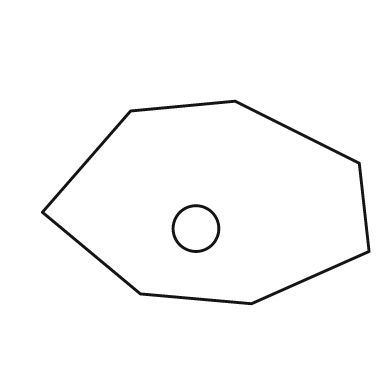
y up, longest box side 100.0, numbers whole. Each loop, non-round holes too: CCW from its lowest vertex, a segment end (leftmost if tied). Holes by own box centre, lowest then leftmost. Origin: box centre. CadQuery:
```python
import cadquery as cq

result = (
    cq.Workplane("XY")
    .moveTo(14.0, -31.0)
    .lineTo(50.0, -15.0)
    .lineTo(47.0, 12.0)
    .lineTo(9.0, 31.0)
    .lineTo(-23.0, 28.0)
    .lineTo(-50.0, -3.0)
    .lineTo(-20.0, -28.0)
    .close()
    .moveTo(-3.0, -8.0)
    .circle(7.0)
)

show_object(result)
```